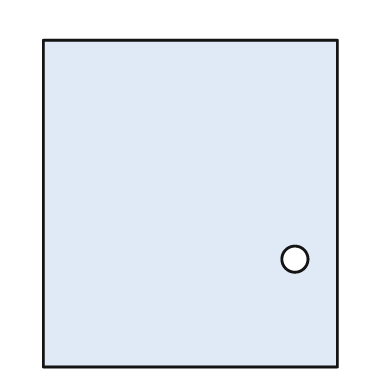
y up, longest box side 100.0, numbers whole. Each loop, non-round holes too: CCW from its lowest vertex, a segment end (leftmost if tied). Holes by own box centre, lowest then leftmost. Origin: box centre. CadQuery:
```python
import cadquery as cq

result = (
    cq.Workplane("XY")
    .moveTo(-45.0, -50.0)
    .lineTo(45.0, -50.0)
    .lineTo(45.0, 50.0)
    .lineTo(-45.0, 50.0)
    .close()
    .moveTo(32.0, -17.0)
    .circle(4.0)
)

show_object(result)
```